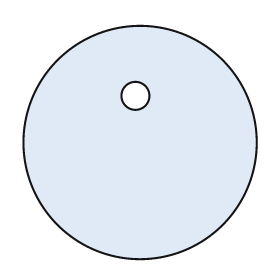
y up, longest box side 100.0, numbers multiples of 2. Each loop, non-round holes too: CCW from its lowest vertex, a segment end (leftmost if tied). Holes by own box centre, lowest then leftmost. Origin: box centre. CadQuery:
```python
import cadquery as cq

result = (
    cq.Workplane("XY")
    .moveTo(0.0, 0.0)
    .circle(50.0)
    .moveTo(-2.0, 20.0)
    .circle(6.0)
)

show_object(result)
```